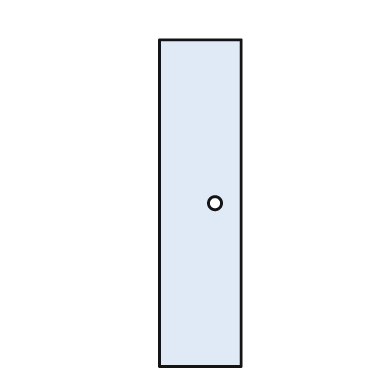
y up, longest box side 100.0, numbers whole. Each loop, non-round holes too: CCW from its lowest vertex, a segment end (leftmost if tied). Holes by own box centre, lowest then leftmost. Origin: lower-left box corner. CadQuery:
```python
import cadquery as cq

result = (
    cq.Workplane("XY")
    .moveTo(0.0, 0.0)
    .lineTo(25.0, 0.0)
    .lineTo(25.0, 100.0)
    .lineTo(0.0, 100.0)
    .close()
    .moveTo(17.0, 50.0)
    .circle(2.0)
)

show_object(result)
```